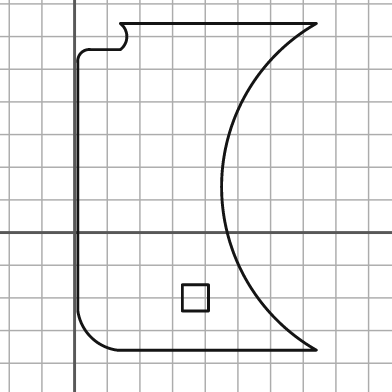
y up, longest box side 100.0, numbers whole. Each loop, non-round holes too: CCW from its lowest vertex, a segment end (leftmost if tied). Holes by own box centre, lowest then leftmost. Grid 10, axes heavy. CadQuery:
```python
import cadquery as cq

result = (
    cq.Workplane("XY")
    .moveTo(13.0, -36.0)
    .lineTo(74.0, -36.0)
    .threePointArc((45.0, 14.0), (74.0, 64.0))
    .lineTo(14.0, 64.0)
    .threePointArc((16.0, 60.0), (14.0, 56.0))
    .lineTo(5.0, 56.0)
    .threePointArc((2.0, 55.0), (1.0, 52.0))
    .lineTo(1.0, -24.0)
    .threePointArc((5.0, -32.0), (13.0, -36.0))
    .close()
    .moveTo(33.0, -24.0)
    .lineTo(41.0, -24.0)
    .lineTo(41.0, -16.0)
    .lineTo(33.0, -16.0)
    .close()
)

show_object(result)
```